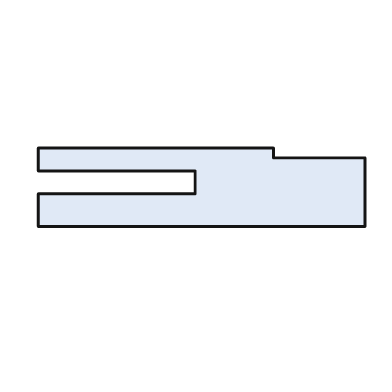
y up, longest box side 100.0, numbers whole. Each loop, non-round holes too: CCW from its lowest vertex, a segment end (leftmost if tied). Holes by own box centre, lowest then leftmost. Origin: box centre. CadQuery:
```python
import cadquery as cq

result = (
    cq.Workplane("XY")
    .moveTo(-50.0, -12.0)
    .lineTo(50.0, -12.0)
    .lineTo(50.0, 9.0)
    .lineTo(22.0, 9.0)
    .lineTo(22.0, 12.0)
    .lineTo(-50.0, 12.0)
    .lineTo(-50.0, 5.0)
    .lineTo(-2.0, 5.0)
    .lineTo(-2.0, -2.0)
    .lineTo(-50.0, -2.0)
    .close()
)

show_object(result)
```